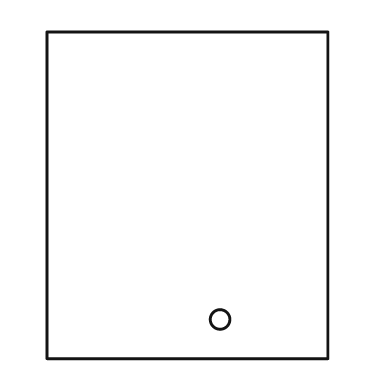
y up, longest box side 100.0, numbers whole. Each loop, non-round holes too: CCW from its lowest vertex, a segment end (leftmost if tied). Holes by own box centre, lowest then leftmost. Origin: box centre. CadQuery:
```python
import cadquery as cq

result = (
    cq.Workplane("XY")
    .moveTo(-43.0, -50.0)
    .lineTo(43.0, -50.0)
    .lineTo(43.0, 50.0)
    .lineTo(-43.0, 50.0)
    .close()
    .moveTo(10.0, -38.0)
    .circle(3.0)
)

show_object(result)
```